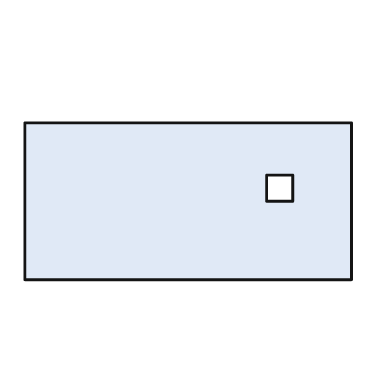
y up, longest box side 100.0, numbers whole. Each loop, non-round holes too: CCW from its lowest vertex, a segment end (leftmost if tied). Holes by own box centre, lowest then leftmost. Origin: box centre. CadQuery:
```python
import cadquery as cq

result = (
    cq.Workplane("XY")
    .moveTo(-50.0, -24.0)
    .lineTo(50.0, -24.0)
    .lineTo(50.0, 24.0)
    .lineTo(-50.0, 24.0)
    .close()
    .moveTo(24.0, 0.0)
    .lineTo(32.0, 0.0)
    .lineTo(32.0, 8.0)
    .lineTo(24.0, 8.0)
    .close()
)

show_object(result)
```